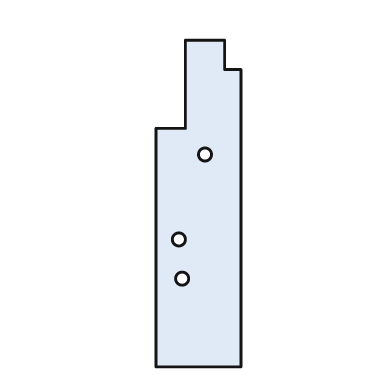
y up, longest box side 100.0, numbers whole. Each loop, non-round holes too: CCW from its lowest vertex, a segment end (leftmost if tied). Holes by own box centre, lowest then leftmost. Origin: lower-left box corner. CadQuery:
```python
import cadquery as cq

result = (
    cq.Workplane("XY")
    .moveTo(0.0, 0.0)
    .lineTo(26.0, 0.0)
    .lineTo(26.0, 91.0)
    .lineTo(21.0, 91.0)
    .lineTo(21.0, 100.0)
    .lineTo(9.0, 100.0)
    .lineTo(9.0, 73.0)
    .lineTo(0.0, 73.0)
    .close()
    .moveTo(8.0, 27.0)
    .circle(2.0)
    .moveTo(7.0, 39.0)
    .circle(2.0)
    .moveTo(15.0, 65.0)
    .circle(2.0)
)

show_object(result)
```